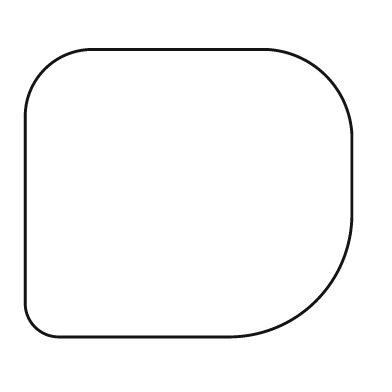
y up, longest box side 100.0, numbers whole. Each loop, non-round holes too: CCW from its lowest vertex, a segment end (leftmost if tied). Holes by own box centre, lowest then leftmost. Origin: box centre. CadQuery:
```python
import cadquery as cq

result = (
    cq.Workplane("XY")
    .moveTo(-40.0, -44.0)
    .lineTo(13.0, -44.0)
    .threePointArc((39.0, -33.0), (50.0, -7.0))
    .lineTo(50.0, 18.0)
    .threePointArc((42.0, 36.0), (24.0, 44.0))
    .lineTo(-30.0, 44.0)
    .threePointArc((-44.0, 38.0), (-50.0, 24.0))
    .lineTo(-50.0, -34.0)
    .threePointArc((-47.0, -41.0), (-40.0, -44.0))
    .close()
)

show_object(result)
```